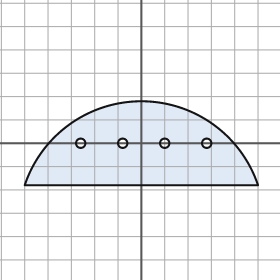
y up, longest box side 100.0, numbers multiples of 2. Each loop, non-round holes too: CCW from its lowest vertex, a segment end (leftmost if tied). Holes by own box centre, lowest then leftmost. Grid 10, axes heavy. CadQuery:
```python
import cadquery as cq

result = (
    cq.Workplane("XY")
    .moveTo(-50.0, -18.0)
    .lineTo(50.0, -18.0)
    .threePointArc((0.0, 18.0), (-50.0, -18.0))
    .close()
    .moveTo(-26.0, 0.0)
    .circle(2.0)
    .moveTo(-8.0, 0.0)
    .circle(2.0)
    .moveTo(10.0, 0.0)
    .circle(2.0)
    .moveTo(28.0, 0.0)
    .circle(2.0)
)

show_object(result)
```